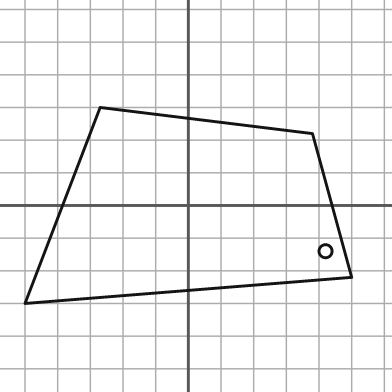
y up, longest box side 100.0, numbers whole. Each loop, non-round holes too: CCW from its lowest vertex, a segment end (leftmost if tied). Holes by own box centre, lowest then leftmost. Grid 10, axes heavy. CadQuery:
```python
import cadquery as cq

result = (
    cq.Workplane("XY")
    .moveTo(-50.0, -30.0)
    .lineTo(50.0, -22.0)
    .lineTo(38.0, 22.0)
    .lineTo(-27.0, 30.0)
    .close()
    .moveTo(42.0, -14.0)
    .circle(2.0)
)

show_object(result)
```